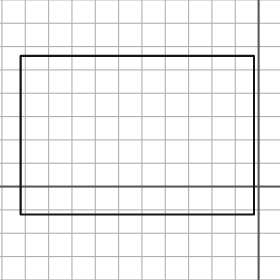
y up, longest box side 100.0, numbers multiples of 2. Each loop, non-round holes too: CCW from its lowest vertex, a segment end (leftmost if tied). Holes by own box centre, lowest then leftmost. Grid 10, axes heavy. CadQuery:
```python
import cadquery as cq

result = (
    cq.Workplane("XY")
    .moveTo(-102.0, -12.0)
    .lineTo(-2.0, -12.0)
    .lineTo(-2.0, 56.0)
    .lineTo(-102.0, 56.0)
    .close()
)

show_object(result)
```